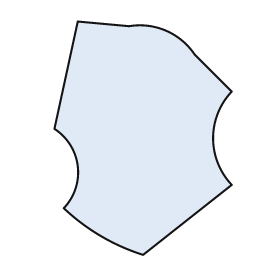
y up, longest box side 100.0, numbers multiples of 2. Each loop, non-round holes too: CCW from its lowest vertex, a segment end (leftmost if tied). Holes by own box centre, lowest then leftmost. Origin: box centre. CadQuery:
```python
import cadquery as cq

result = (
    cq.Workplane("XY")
    .moveTo(0.0, -50.0)
    .lineTo(38.0, -20.0)
    .threePointArc((30.0, 0.0), (38.0, 20.0))
    .lineTo(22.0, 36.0)
    .threePointArc((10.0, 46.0), (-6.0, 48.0))
    .lineTo(-28.0, 50.0)
    .lineTo(-38.0, 4.0)
    .threePointArc((-28.0, -12.0), (-34.0, -30.0))
    .threePointArc((-18.0, -42.0), (0.0, -50.0))
    .close()
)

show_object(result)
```